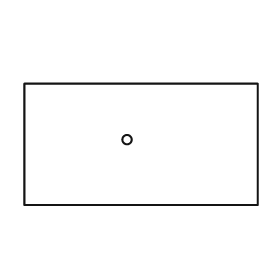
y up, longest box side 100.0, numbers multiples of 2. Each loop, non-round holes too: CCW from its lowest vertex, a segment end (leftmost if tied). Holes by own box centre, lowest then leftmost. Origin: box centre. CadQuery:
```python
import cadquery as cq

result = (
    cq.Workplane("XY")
    .moveTo(-50.0, -26.0)
    .lineTo(50.0, -26.0)
    .lineTo(50.0, 26.0)
    .lineTo(-50.0, 26.0)
    .close()
    .moveTo(-6.0, 2.0)
    .circle(2.0)
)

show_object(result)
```